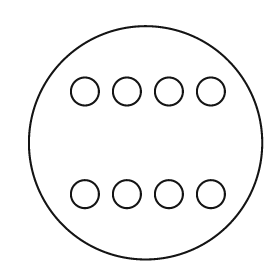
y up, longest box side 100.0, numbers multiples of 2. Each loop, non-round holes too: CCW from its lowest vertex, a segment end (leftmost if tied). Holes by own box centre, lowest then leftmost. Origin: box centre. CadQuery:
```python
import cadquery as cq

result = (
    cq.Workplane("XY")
    .moveTo(0.0, 0.0)
    .circle(50.0)
    .moveTo(-26.0, -22.0)
    .circle(6.0)
    .moveTo(-8.0, -22.0)
    .circle(6.0)
    .moveTo(10.0, -22.0)
    .circle(6.0)
    .moveTo(28.0, -22.0)
    .circle(6.0)
    .moveTo(-26.0, 22.0)
    .circle(6.0)
    .moveTo(-8.0, 22.0)
    .circle(6.0)
    .moveTo(10.0, 22.0)
    .circle(6.0)
    .moveTo(28.0, 22.0)
    .circle(6.0)
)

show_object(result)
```